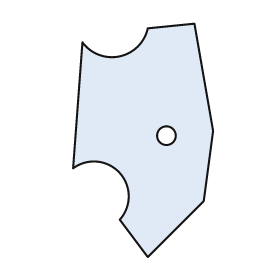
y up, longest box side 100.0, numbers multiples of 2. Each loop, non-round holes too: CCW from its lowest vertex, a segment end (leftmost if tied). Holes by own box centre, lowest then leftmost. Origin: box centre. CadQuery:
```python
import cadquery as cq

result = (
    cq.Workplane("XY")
    .moveTo(2.0, -50.0)
    .lineTo(26.0, -26.0)
    .lineTo(30.0, 4.0)
    .lineTo(22.0, 50.0)
    .lineTo(2.0, 48.0)
    .threePointArc((-10.0, 36.0), (-26.0, 42.0))
    .lineTo(-30.0, -12.0)
    .threePointArc((-10.0, -14.0), (-10.0, -34.0))
    .close()
    .moveTo(10.0, 2.0)
    .circle(4.0)
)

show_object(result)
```